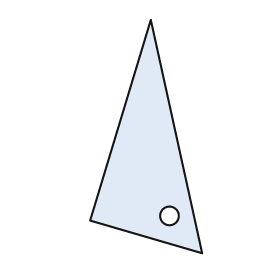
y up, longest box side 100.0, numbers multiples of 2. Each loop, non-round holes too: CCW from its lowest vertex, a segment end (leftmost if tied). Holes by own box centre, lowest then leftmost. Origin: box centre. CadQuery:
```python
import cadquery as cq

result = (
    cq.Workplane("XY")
    .moveTo(24.0, -50.0)
    .lineTo(2.0, 50.0)
    .lineTo(-24.0, -36.0)
    .close()
    .moveTo(10.0, -34.0)
    .circle(4.0)
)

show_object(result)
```